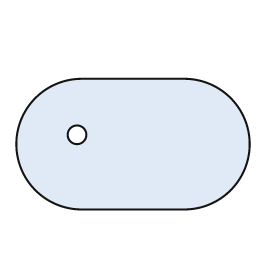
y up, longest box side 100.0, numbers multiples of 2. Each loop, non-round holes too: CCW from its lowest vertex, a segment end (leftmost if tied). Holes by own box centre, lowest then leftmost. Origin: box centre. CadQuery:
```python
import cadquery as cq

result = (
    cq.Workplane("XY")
    .moveTo(-22.0, -28.0)
    .lineTo(22.0, -28.0)
    .threePointArc((50.0, 0.0), (22.0, 28.0))
    .lineTo(-22.0, 28.0)
    .threePointArc((-50.0, 0.0), (-22.0, -28.0))
    .close()
    .moveTo(-24.0, 4.0)
    .circle(4.0)
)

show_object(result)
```